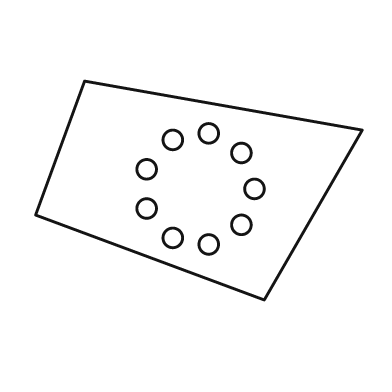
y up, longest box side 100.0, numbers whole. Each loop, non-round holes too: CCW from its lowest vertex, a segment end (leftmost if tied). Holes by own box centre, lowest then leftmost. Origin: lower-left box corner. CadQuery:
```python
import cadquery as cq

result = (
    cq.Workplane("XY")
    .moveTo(70.0, 0.0)
    .lineTo(100.0, 52.0)
    .lineTo(15.0, 67.0)
    .lineTo(0.0, 26.0)
    .close()
    .moveTo(53.0, 17.0)
    .circle(3.0)
    .moveTo(42.0, 19.0)
    .circle(3.0)
    .moveTo(63.0, 23.0)
    .circle(3.0)
    .moveTo(34.0, 28.0)
    .circle(3.0)
    .moveTo(67.0, 34.0)
    .circle(3.0)
    .moveTo(34.0, 40.0)
    .circle(3.0)
    .moveTo(63.0, 45.0)
    .circle(3.0)
    .moveTo(42.0, 49.0)
    .circle(3.0)
    .moveTo(53.0, 51.0)
    .circle(3.0)
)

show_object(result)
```